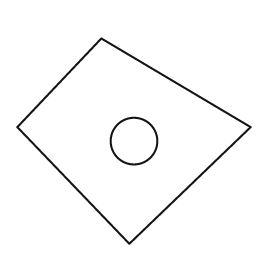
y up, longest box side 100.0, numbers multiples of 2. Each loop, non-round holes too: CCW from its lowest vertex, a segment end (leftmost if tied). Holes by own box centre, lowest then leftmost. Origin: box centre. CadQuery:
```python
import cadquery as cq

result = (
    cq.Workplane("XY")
    .moveTo(-2.0, -44.0)
    .lineTo(50.0, 6.0)
    .lineTo(-14.0, 44.0)
    .lineTo(-50.0, 6.0)
    .close()
    .moveTo(0.0, 0.0)
    .circle(10.0)
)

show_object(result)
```